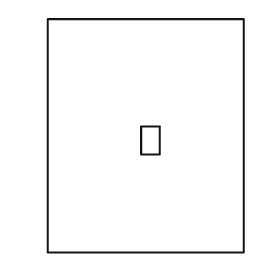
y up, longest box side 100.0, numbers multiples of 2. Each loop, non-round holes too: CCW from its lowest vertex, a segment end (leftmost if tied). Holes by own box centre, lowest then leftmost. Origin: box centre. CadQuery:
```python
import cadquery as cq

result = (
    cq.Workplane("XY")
    .moveTo(-42.0, -50.0)
    .lineTo(42.0, -50.0)
    .lineTo(42.0, 50.0)
    .lineTo(-42.0, 50.0)
    .close()
    .moveTo(-2.0, -8.0)
    .lineTo(6.0, -8.0)
    .lineTo(6.0, 4.0)
    .lineTo(-2.0, 4.0)
    .close()
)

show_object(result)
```